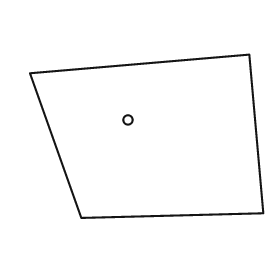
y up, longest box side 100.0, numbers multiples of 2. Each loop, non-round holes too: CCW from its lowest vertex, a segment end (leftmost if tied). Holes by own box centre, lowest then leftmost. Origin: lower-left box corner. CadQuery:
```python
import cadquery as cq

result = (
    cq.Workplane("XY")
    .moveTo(22.0, 0.0)
    .lineTo(100.0, 2.0)
    .lineTo(94.0, 70.0)
    .lineTo(0.0, 62.0)
    .close()
    .moveTo(42.0, 42.0)
    .circle(2.0)
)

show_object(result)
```